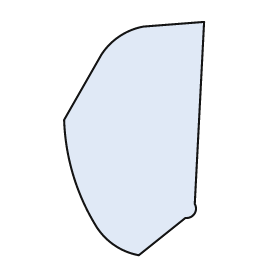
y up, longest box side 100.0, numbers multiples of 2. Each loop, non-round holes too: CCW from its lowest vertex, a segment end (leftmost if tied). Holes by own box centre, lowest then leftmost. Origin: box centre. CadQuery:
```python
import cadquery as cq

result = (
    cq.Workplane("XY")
    .moveTo(2.0, -50.0)
    .lineTo(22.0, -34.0)
    .threePointArc((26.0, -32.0), (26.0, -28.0))
    .lineTo(30.0, 50.0)
    .lineTo(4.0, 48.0)
    .threePointArc((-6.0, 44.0), (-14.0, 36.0))
    .lineTo(-30.0, 8.0)
    .threePointArc((-26.0, -16.0), (-16.0, -38.0))
    .threePointArc((-8.0, -46.0), (2.0, -50.0))
    .close()
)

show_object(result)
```